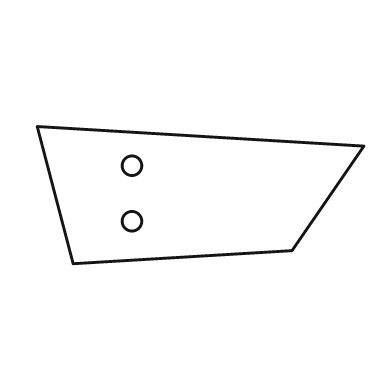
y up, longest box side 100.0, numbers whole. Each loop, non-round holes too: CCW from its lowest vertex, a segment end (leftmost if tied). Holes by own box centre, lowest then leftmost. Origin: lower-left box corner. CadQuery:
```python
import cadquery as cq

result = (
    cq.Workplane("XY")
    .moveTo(11.0, 0.0)
    .lineTo(78.0, 4.0)
    .lineTo(100.0, 36.0)
    .lineTo(0.0, 42.0)
    .close()
    .moveTo(29.0, 13.0)
    .circle(3.0)
    .moveTo(29.0, 30.0)
    .circle(3.0)
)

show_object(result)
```